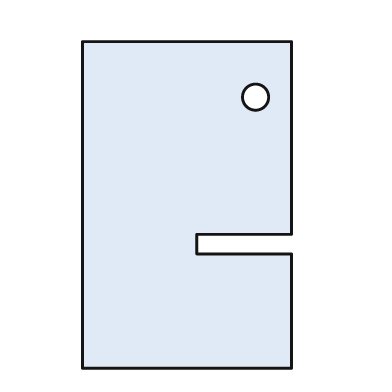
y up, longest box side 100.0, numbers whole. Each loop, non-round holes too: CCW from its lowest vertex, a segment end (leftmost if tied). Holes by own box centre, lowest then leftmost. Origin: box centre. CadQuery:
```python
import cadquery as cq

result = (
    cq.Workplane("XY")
    .moveTo(-32.0, -50.0)
    .lineTo(32.0, -50.0)
    .lineTo(32.0, -15.0)
    .lineTo(3.0, -15.0)
    .lineTo(3.0, -9.0)
    .lineTo(32.0, -9.0)
    .lineTo(32.0, 50.0)
    .lineTo(-32.0, 50.0)
    .close()
    .moveTo(21.0, 33.0)
    .circle(4.0)
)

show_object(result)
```